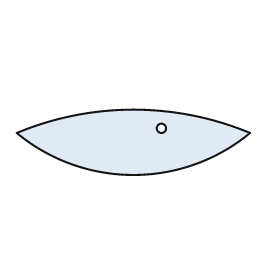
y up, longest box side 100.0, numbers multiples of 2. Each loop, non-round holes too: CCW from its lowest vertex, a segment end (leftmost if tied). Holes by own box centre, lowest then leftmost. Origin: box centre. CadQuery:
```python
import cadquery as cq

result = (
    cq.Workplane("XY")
    .moveTo(-50.0, 4.0)
    .threePointArc((0.0, -14.0), (50.0, 4.0))
    .threePointArc((0.0, 14.0), (-50.0, 4.0))
    .close()
    .moveTo(12.0, 6.0)
    .circle(2.0)
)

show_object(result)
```